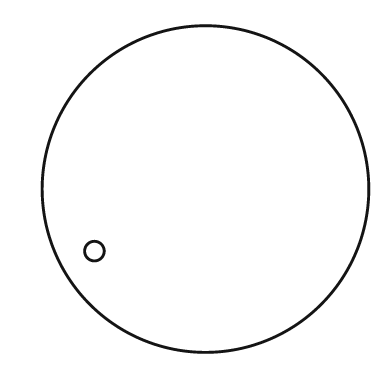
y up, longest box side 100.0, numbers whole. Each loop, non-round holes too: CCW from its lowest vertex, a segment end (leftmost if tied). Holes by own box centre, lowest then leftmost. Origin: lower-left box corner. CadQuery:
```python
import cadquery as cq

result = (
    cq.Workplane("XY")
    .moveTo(50.0, 50.0)
    .circle(50.0)
    .moveTo(16.0, 31.0)
    .circle(3.0)
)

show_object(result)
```